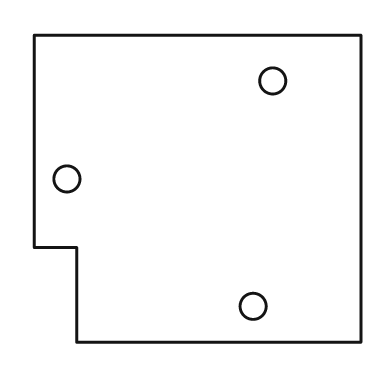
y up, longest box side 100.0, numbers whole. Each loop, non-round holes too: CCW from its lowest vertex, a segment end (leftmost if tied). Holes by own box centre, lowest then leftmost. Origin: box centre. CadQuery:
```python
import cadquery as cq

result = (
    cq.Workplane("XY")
    .moveTo(-37.0, -47.0)
    .lineTo(50.0, -47.0)
    .lineTo(50.0, 47.0)
    .lineTo(-50.0, 47.0)
    .lineTo(-50.0, -18.0)
    .lineTo(-37.0, -18.0)
    .close()
    .moveTo(17.0, -36.0)
    .circle(4.0)
    .moveTo(-40.0, 3.0)
    .circle(4.0)
    .moveTo(23.0, 33.0)
    .circle(4.0)
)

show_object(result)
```